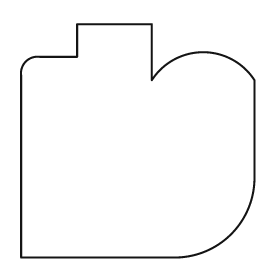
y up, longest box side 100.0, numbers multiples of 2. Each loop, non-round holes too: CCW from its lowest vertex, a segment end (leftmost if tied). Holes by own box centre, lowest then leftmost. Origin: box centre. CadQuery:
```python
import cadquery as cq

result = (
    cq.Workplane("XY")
    .moveTo(-50.0, -50.0)
    .lineTo(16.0, -50.0)
    .threePointArc((40.0, -40.0), (50.0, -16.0))
    .lineTo(50.0, 26.0)
    .threePointArc((28.0, 38.0), (6.0, 26.0))
    .lineTo(6.0, 50.0)
    .lineTo(-26.0, 50.0)
    .lineTo(-26.0, 36.0)
    .lineTo(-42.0, 36.0)
    .threePointArc((-48.0, 34.0), (-50.0, 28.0))
    .close()
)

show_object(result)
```